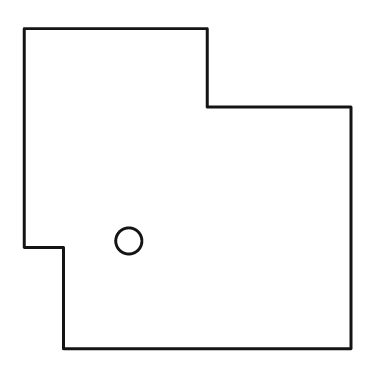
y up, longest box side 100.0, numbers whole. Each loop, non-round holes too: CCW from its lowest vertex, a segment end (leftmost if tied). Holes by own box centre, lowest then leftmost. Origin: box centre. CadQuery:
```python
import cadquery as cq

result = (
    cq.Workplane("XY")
    .moveTo(-38.0, -49.0)
    .lineTo(50.0, -49.0)
    .lineTo(50.0, 25.0)
    .lineTo(6.0, 25.0)
    .lineTo(6.0, 49.0)
    .lineTo(-50.0, 49.0)
    .lineTo(-50.0, -18.0)
    .lineTo(-38.0, -18.0)
    .close()
    .moveTo(-18.0, -16.0)
    .circle(4.0)
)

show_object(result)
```